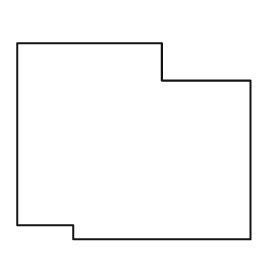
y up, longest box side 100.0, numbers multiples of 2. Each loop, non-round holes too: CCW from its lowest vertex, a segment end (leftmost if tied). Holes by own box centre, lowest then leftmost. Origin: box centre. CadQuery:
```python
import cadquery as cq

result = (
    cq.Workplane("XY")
    .moveTo(-26.0, -42.0)
    .lineTo(50.0, -42.0)
    .lineTo(50.0, 26.0)
    .lineTo(12.0, 26.0)
    .lineTo(12.0, 42.0)
    .lineTo(-50.0, 42.0)
    .lineTo(-50.0, -36.0)
    .lineTo(-26.0, -36.0)
    .close()
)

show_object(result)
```